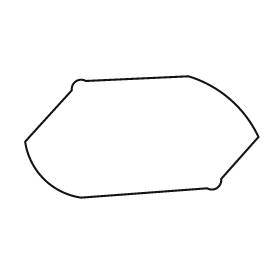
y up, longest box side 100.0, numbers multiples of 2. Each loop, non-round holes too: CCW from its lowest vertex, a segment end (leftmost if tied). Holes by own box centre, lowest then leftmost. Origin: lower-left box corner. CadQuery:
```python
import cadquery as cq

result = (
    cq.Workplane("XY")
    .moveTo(24.0, 0.0)
    .lineTo(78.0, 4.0)
    .threePointArc((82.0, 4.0), (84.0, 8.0))
    .lineTo(100.0, 26.0)
    .threePointArc((88.0, 42.0), (70.0, 52.0))
    .lineTo(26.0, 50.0)
    .threePointArc((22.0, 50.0), (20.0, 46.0))
    .lineTo(0.0, 24.0)
    .threePointArc((8.0, 8.0), (24.0, 0.0))
    .close()
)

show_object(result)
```